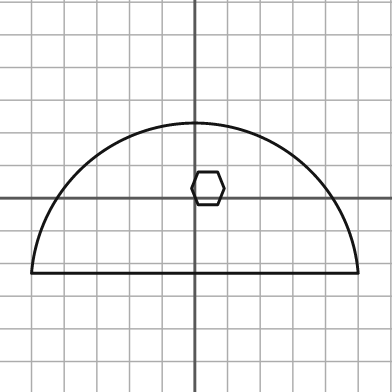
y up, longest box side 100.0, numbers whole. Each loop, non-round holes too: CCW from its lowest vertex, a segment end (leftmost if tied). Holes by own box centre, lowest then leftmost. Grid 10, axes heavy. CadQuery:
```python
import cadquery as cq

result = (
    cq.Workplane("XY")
    .moveTo(-50.0, -23.0)
    .lineTo(50.0, -23.0)
    .threePointArc((0.0, 23.0), (-50.0, -23.0))
    .close()
    .moveTo(1.0, -2.0)
    .lineTo(7.0, -2.0)
    .lineTo(9.0, 3.0)
    .lineTo(7.0, 8.0)
    .lineTo(1.0, 8.0)
    .lineTo(-1.0, 3.0)
    .close()
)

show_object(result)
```